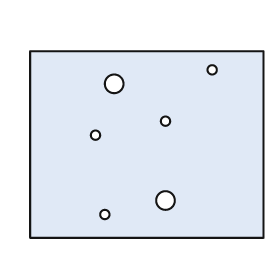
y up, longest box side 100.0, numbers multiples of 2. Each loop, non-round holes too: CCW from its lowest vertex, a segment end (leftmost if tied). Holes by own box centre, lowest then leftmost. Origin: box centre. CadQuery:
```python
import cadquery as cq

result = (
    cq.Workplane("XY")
    .moveTo(-50.0, -40.0)
    .lineTo(50.0, -40.0)
    .lineTo(50.0, 40.0)
    .lineTo(-50.0, 40.0)
    .close()
    .moveTo(-18.0, -30.0)
    .circle(2.0)
    .moveTo(8.0, -24.0)
    .circle(4.0)
    .moveTo(-22.0, 4.0)
    .circle(2.0)
    .moveTo(8.0, 10.0)
    .circle(2.0)
    .moveTo(-14.0, 26.0)
    .circle(4.0)
    .moveTo(28.0, 32.0)
    .circle(2.0)
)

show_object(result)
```